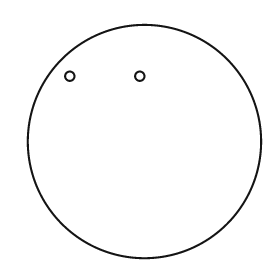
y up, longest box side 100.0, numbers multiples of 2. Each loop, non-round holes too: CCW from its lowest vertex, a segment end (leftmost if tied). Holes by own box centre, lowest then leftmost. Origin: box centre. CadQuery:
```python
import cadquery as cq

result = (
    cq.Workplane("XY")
    .moveTo(0.0, 0.0)
    .circle(50.0)
    .moveTo(-32.0, 28.0)
    .circle(2.0)
    .moveTo(-2.0, 28.0)
    .circle(2.0)
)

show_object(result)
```